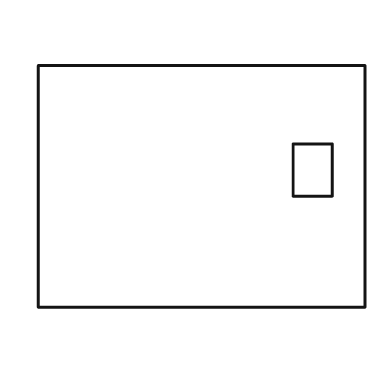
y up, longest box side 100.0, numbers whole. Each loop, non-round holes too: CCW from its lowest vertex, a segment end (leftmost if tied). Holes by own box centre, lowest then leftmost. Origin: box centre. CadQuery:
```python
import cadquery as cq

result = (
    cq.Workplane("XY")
    .moveTo(-50.0, -37.0)
    .lineTo(50.0, -37.0)
    .lineTo(50.0, 37.0)
    .lineTo(-50.0, 37.0)
    .close()
    .moveTo(28.0, -3.0)
    .lineTo(40.0, -3.0)
    .lineTo(40.0, 13.0)
    .lineTo(28.0, 13.0)
    .close()
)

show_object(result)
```